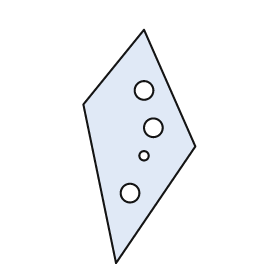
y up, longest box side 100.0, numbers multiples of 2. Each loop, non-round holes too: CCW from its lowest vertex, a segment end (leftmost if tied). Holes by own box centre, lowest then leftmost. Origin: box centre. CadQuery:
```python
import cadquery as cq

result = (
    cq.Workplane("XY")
    .moveTo(-10.0, -50.0)
    .lineTo(24.0, 0.0)
    .lineTo(2.0, 50.0)
    .lineTo(-24.0, 18.0)
    .close()
    .moveTo(-4.0, -20.0)
    .circle(4.0)
    .moveTo(2.0, -4.0)
    .circle(2.0)
    .moveTo(6.0, 8.0)
    .circle(4.0)
    .moveTo(2.0, 24.0)
    .circle(4.0)
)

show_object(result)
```